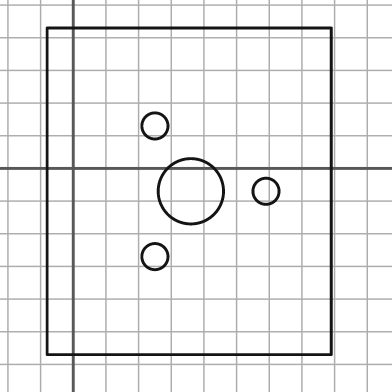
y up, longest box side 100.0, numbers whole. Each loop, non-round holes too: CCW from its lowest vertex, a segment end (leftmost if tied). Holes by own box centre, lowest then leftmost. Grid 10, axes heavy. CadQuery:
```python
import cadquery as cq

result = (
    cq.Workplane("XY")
    .moveTo(-8.0, -57.0)
    .lineTo(79.0, -57.0)
    .lineTo(79.0, 43.0)
    .lineTo(-8.0, 43.0)
    .close()
    .moveTo(25.0, -27.0)
    .circle(4.0)
    .moveTo(36.0, -7.0)
    .circle(10.0)
    .moveTo(59.0, -7.0)
    .circle(4.0)
    .moveTo(25.0, 13.0)
    .circle(4.0)
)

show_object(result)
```